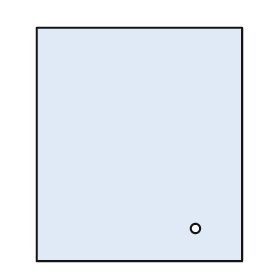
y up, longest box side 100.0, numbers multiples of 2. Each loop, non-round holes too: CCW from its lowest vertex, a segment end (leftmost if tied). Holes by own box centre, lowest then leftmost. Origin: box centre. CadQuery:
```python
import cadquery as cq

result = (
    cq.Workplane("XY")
    .moveTo(-44.0, -50.0)
    .lineTo(44.0, -50.0)
    .lineTo(44.0, 50.0)
    .lineTo(-44.0, 50.0)
    .close()
    .moveTo(24.0, -36.0)
    .circle(2.0)
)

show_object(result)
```